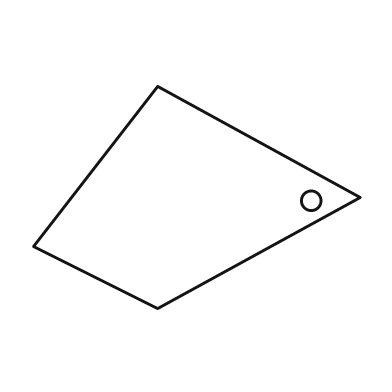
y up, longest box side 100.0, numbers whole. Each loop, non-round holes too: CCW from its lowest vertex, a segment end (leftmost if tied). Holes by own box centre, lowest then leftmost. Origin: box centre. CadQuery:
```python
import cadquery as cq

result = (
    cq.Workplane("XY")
    .moveTo(-12.0, -34.0)
    .lineTo(50.0, 0.0)
    .lineTo(-12.0, 34.0)
    .lineTo(-50.0, -15.0)
    .close()
    .moveTo(35.0, -1.0)
    .circle(3.0)
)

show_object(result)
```